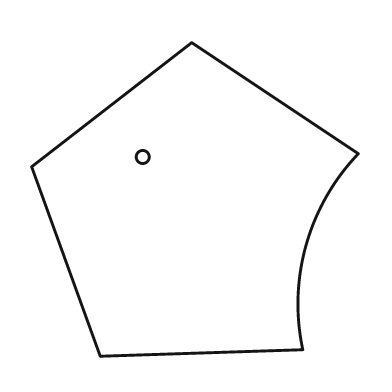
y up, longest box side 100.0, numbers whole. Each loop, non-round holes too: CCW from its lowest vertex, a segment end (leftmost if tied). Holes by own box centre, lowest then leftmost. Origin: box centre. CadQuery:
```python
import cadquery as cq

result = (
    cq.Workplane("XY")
    .moveTo(-29.0, -48.0)
    .lineTo(33.0, -46.0)
    .threePointArc((34.0, -14.0), (50.0, 14.0))
    .lineTo(-1.0, 48.0)
    .lineTo(-50.0, 10.0)
    .close()
    .moveTo(-16.0, 13.0)
    .circle(2.0)
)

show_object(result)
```